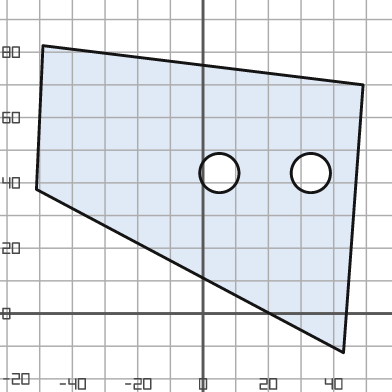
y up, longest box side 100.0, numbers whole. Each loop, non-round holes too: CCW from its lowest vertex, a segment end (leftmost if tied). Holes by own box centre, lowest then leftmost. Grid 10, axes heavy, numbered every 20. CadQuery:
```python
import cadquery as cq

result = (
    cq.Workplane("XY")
    .moveTo(43.0, -12.0)
    .lineTo(49.0, 70.0)
    .lineTo(-49.0, 82.0)
    .lineTo(-51.0, 38.0)
    .close()
    .moveTo(5.0, 43.0)
    .circle(6.0)
    .moveTo(33.0, 43.0)
    .circle(6.0)
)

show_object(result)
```